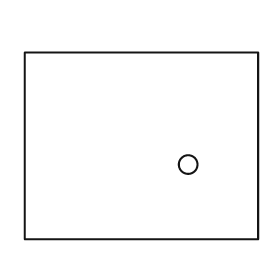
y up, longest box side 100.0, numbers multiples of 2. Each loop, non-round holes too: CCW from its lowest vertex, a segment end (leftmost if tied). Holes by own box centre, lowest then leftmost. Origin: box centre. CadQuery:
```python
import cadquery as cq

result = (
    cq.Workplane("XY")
    .moveTo(-50.0, -40.0)
    .lineTo(50.0, -40.0)
    .lineTo(50.0, 40.0)
    .lineTo(-50.0, 40.0)
    .close()
    .moveTo(20.0, -8.0)
    .circle(4.0)
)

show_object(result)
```